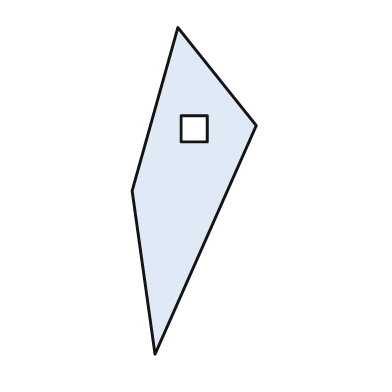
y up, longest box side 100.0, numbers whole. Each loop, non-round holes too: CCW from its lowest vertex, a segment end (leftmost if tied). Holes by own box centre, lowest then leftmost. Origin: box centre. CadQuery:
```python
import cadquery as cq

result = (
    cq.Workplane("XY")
    .moveTo(-12.0, -50.0)
    .lineTo(19.0, 20.0)
    .lineTo(-5.0, 50.0)
    .lineTo(-19.0, 0.0)
    .close()
    .moveTo(-4.0, 15.0)
    .lineTo(4.0, 15.0)
    .lineTo(4.0, 23.0)
    .lineTo(-4.0, 23.0)
    .close()
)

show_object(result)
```